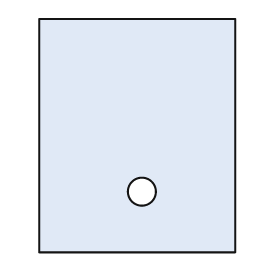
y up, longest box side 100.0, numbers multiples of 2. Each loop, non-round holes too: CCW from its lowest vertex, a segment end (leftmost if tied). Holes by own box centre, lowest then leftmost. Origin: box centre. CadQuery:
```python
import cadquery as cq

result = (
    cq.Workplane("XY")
    .moveTo(-42.0, -50.0)
    .lineTo(42.0, -50.0)
    .lineTo(42.0, 50.0)
    .lineTo(-42.0, 50.0)
    .close()
    .moveTo(2.0, -24.0)
    .circle(6.0)
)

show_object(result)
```